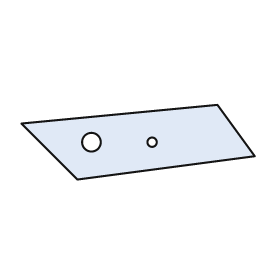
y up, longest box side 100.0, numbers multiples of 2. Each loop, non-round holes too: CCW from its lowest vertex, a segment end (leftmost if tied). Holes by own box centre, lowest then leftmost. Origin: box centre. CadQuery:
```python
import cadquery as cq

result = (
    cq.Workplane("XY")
    .moveTo(-26.0, -16.0)
    .lineTo(50.0, -6.0)
    .lineTo(34.0, 16.0)
    .lineTo(-50.0, 8.0)
    .close()
    .moveTo(-20.0, 0.0)
    .circle(4.0)
    .moveTo(6.0, 0.0)
    .circle(2.0)
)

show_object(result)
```